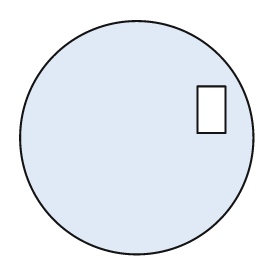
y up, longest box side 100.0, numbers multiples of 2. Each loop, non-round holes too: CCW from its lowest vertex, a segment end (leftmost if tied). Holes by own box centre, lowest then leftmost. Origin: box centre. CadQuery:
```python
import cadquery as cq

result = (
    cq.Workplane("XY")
    .moveTo(0.0, 0.0)
    .circle(50.0)
    .moveTo(26.0, 2.0)
    .lineTo(38.0, 2.0)
    .lineTo(38.0, 22.0)
    .lineTo(26.0, 22.0)
    .close()
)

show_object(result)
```